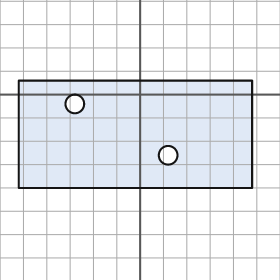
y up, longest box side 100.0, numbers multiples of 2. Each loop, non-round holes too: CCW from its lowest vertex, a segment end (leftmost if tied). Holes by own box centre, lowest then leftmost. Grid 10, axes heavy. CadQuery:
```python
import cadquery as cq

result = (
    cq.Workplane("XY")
    .moveTo(-52.0, -40.0)
    .lineTo(48.0, -40.0)
    .lineTo(48.0, 6.0)
    .lineTo(-52.0, 6.0)
    .close()
    .moveTo(12.0, -26.0)
    .circle(4.0)
    .moveTo(-28.0, -4.0)
    .circle(4.0)
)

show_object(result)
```